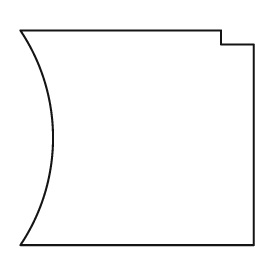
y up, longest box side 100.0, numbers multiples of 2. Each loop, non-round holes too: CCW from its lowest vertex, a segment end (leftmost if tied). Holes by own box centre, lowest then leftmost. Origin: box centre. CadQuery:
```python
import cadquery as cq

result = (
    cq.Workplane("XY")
    .moveTo(-50.0, -46.0)
    .lineTo(50.0, -46.0)
    .lineTo(50.0, 40.0)
    .lineTo(36.0, 40.0)
    .lineTo(36.0, 46.0)
    .lineTo(-50.0, 46.0)
    .threePointArc((-36.0, 0.0), (-50.0, -46.0))
    .close()
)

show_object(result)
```